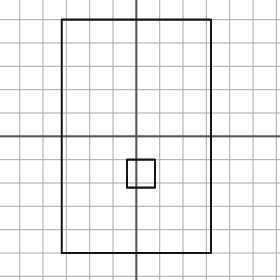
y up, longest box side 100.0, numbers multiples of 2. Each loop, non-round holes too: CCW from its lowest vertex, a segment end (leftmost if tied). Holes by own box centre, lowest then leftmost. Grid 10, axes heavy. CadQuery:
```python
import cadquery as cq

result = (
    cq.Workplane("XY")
    .moveTo(-32.0, -50.0)
    .lineTo(32.0, -50.0)
    .lineTo(32.0, 50.0)
    .lineTo(-32.0, 50.0)
    .close()
    .moveTo(-4.0, -22.0)
    .lineTo(8.0, -22.0)
    .lineTo(8.0, -10.0)
    .lineTo(-4.0, -10.0)
    .close()
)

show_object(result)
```